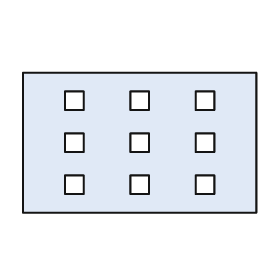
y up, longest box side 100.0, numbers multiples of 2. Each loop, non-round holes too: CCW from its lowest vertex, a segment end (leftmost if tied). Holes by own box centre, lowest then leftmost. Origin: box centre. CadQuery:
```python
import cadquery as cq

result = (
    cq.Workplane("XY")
    .moveTo(-50.0, -30.0)
    .lineTo(50.0, -30.0)
    .lineTo(50.0, 30.0)
    .lineTo(-50.0, 30.0)
    .close()
    .moveTo(-32.0, -22.0)
    .lineTo(-24.0, -22.0)
    .lineTo(-24.0, -14.0)
    .lineTo(-32.0, -14.0)
    .close()
    .moveTo(-4.0, -22.0)
    .lineTo(4.0, -22.0)
    .lineTo(4.0, -14.0)
    .lineTo(-4.0, -14.0)
    .close()
    .moveTo(24.0, -22.0)
    .lineTo(32.0, -22.0)
    .lineTo(32.0, -14.0)
    .lineTo(24.0, -14.0)
    .close()
    .moveTo(-32.0, -4.0)
    .lineTo(-24.0, -4.0)
    .lineTo(-24.0, 4.0)
    .lineTo(-32.0, 4.0)
    .close()
    .moveTo(-4.0, -4.0)
    .lineTo(4.0, -4.0)
    .lineTo(4.0, 4.0)
    .lineTo(-4.0, 4.0)
    .close()
    .moveTo(24.0, -4.0)
    .lineTo(32.0, -4.0)
    .lineTo(32.0, 4.0)
    .lineTo(24.0, 4.0)
    .close()
    .moveTo(-32.0, 14.0)
    .lineTo(-24.0, 14.0)
    .lineTo(-24.0, 22.0)
    .lineTo(-32.0, 22.0)
    .close()
    .moveTo(-4.0, 14.0)
    .lineTo(4.0, 14.0)
    .lineTo(4.0, 22.0)
    .lineTo(-4.0, 22.0)
    .close()
    .moveTo(24.0, 14.0)
    .lineTo(32.0, 14.0)
    .lineTo(32.0, 22.0)
    .lineTo(24.0, 22.0)
    .close()
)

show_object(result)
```